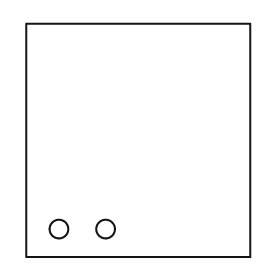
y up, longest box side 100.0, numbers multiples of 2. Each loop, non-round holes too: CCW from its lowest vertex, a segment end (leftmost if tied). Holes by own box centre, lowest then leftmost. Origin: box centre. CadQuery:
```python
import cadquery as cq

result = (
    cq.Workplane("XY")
    .moveTo(-48.0, -50.0)
    .lineTo(48.0, -50.0)
    .lineTo(48.0, 50.0)
    .lineTo(-48.0, 50.0)
    .close()
    .moveTo(-34.0, -38.0)
    .circle(4.0)
    .moveTo(-14.0, -38.0)
    .circle(4.0)
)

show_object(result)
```